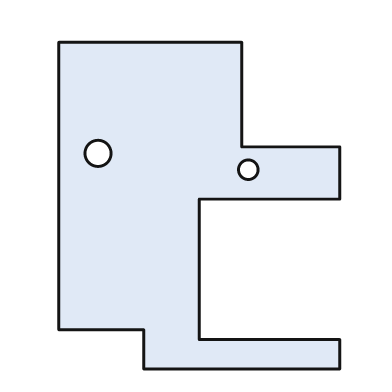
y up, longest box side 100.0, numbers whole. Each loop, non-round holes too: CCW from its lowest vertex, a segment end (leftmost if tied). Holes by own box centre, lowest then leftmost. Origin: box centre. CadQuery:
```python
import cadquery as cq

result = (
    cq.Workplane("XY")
    .moveTo(-17.0, -50.0)
    .lineTo(43.0, -50.0)
    .lineTo(43.0, -41.0)
    .lineTo(0.0, -41.0)
    .lineTo(0.0, 2.0)
    .lineTo(43.0, 2.0)
    .lineTo(43.0, 18.0)
    .lineTo(13.0, 18.0)
    .lineTo(13.0, 50.0)
    .lineTo(-43.0, 50.0)
    .lineTo(-43.0, -38.0)
    .lineTo(-17.0, -38.0)
    .close()
    .moveTo(15.0, 11.0)
    .circle(3.0)
    .moveTo(-31.0, 16.0)
    .circle(4.0)
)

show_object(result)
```